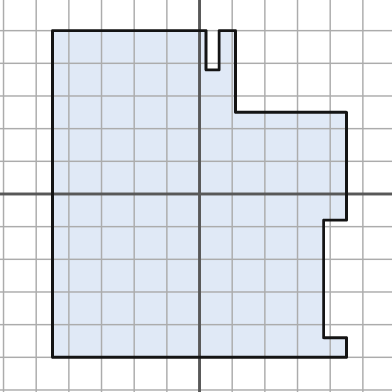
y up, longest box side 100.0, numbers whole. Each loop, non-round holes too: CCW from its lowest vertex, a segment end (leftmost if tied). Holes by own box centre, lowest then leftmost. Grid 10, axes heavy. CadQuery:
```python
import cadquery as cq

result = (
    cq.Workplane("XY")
    .moveTo(-45.0, -50.0)
    .lineTo(45.0, -50.0)
    .lineTo(45.0, -44.0)
    .lineTo(38.0, -44.0)
    .lineTo(38.0, -8.0)
    .lineTo(45.0, -8.0)
    .lineTo(45.0, 25.0)
    .lineTo(11.0, 25.0)
    .lineTo(11.0, 50.0)
    .lineTo(6.0, 50.0)
    .lineTo(6.0, 38.0)
    .lineTo(2.0, 38.0)
    .lineTo(2.0, 50.0)
    .lineTo(-45.0, 50.0)
    .close()
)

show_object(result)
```